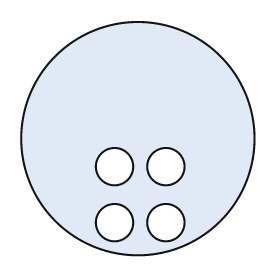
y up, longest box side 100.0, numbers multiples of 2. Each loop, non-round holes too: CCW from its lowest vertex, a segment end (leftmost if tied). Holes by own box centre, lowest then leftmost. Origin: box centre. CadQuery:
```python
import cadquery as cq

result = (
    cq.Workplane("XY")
    .moveTo(0.0, 0.0)
    .circle(50.0)
    .moveTo(-10.0, -36.0)
    .circle(8.0)
    .moveTo(12.0, -36.0)
    .circle(8.0)
    .moveTo(-10.0, -12.0)
    .circle(8.0)
    .moveTo(12.0, -12.0)
    .circle(8.0)
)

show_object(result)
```